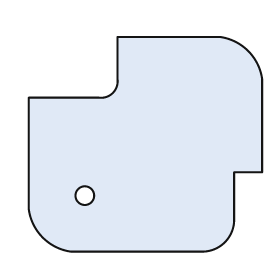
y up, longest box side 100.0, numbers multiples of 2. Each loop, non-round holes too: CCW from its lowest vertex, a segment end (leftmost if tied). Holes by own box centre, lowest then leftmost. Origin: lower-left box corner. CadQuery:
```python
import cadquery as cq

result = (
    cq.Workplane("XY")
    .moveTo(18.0, 0.0)
    .lineTo(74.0, 0.0)
    .threePointArc((84.0, 4.0), (88.0, 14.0))
    .lineTo(88.0, 34.0)
    .lineTo(100.0, 34.0)
    .lineTo(100.0, 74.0)
    .threePointArc((94.0, 86.0), (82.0, 92.0))
    .lineTo(38.0, 92.0)
    .lineTo(38.0, 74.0)
    .threePointArc((36.0, 68.0), (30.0, 66.0))
    .lineTo(0.0, 66.0)
    .lineTo(0.0, 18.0)
    .threePointArc((6.0, 6.0), (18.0, 0.0))
    .close()
    .moveTo(24.0, 24.0)
    .circle(4.0)
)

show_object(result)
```